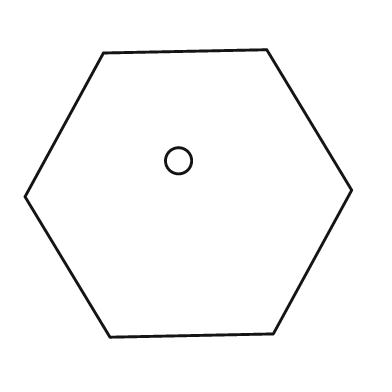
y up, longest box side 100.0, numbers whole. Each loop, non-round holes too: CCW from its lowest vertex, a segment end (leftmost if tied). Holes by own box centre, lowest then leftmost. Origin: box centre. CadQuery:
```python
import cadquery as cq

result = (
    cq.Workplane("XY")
    .moveTo(-24.0, -44.0)
    .lineTo(26.0, -43.0)
    .lineTo(50.0, 1.0)
    .lineTo(24.0, 44.0)
    .lineTo(-26.0, 43.0)
    .lineTo(-50.0, -1.0)
    .close()
    .moveTo(-3.0, 10.0)
    .circle(4.0)
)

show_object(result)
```